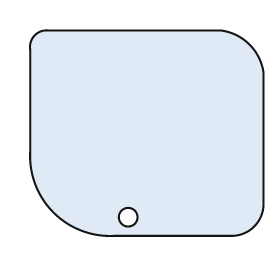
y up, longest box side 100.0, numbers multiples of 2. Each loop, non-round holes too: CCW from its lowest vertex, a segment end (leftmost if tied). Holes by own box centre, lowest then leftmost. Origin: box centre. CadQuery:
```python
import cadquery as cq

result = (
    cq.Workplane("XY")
    .moveTo(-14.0, -44.0)
    .lineTo(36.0, -44.0)
    .threePointArc((46.0, -40.0), (50.0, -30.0))
    .lineTo(50.0, 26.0)
    .threePointArc((44.0, 38.0), (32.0, 44.0))
    .lineTo(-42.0, 44.0)
    .threePointArc((-48.0, 42.0), (-50.0, 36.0))
    .lineTo(-50.0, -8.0)
    .threePointArc((-40.0, -34.0), (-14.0, -44.0))
    .close()
    .moveTo(-8.0, -36.0)
    .circle(4.0)
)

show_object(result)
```